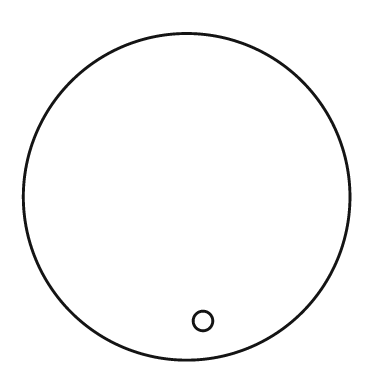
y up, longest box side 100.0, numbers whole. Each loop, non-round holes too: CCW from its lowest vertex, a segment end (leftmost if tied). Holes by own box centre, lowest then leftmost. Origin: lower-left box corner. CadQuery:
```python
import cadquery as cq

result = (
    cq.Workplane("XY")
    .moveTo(50.0, 50.0)
    .circle(50.0)
    .moveTo(55.0, 12.0)
    .circle(3.0)
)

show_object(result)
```